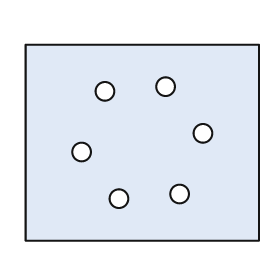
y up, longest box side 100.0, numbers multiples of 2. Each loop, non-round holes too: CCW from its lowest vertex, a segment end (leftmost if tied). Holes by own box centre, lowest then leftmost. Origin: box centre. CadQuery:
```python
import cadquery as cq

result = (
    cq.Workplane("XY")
    .moveTo(-50.0, -42.0)
    .lineTo(50.0, -42.0)
    .lineTo(50.0, 42.0)
    .lineTo(-50.0, 42.0)
    .close()
    .moveTo(-10.0, -24.0)
    .circle(4.0)
    .moveTo(16.0, -22.0)
    .circle(4.0)
    .moveTo(-26.0, -4.0)
    .circle(4.0)
    .moveTo(26.0, 4.0)
    .circle(4.0)
    .moveTo(-16.0, 22.0)
    .circle(4.0)
    .moveTo(10.0, 24.0)
    .circle(4.0)
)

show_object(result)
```